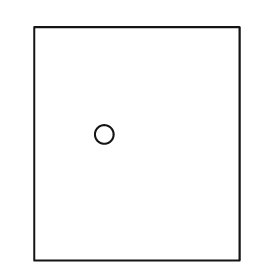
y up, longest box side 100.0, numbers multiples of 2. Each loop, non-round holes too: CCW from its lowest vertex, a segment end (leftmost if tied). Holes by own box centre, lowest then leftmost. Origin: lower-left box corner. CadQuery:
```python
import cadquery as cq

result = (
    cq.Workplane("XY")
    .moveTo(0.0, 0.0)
    .lineTo(88.0, 0.0)
    .lineTo(88.0, 100.0)
    .lineTo(0.0, 100.0)
    .close()
    .moveTo(30.0, 54.0)
    .circle(4.0)
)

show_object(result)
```